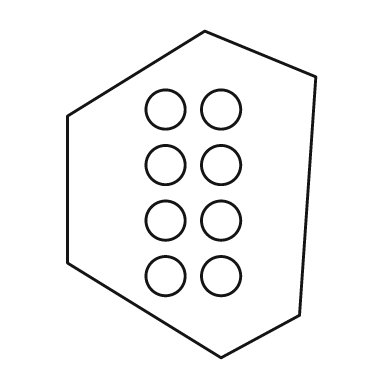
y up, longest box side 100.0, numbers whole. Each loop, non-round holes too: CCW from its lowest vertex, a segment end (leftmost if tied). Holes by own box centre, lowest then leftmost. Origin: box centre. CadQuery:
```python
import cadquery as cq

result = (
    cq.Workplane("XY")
    .moveTo(9.0, -50.0)
    .lineTo(33.0, -37.0)
    .lineTo(38.0, 36.0)
    .lineTo(4.0, 50.0)
    .lineTo(-38.0, 24.0)
    .lineTo(-38.0, -21.0)
    .close()
    .moveTo(-8.0, -25.0)
    .circle(6.0)
    .moveTo(9.0, -25.0)
    .circle(6.0)
    .moveTo(-8.0, -8.0)
    .circle(6.0)
    .moveTo(9.0, -8.0)
    .circle(6.0)
    .moveTo(-8.0, 9.0)
    .circle(6.0)
    .moveTo(9.0, 9.0)
    .circle(6.0)
    .moveTo(-8.0, 26.0)
    .circle(6.0)
    .moveTo(9.0, 26.0)
    .circle(6.0)
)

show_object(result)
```